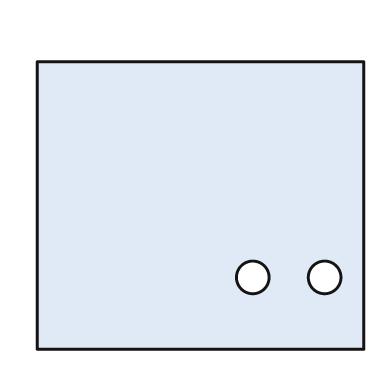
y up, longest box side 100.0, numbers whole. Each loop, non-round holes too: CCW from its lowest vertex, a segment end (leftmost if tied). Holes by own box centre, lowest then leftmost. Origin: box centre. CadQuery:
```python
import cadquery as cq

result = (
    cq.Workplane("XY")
    .moveTo(-50.0, -44.0)
    .lineTo(50.0, -44.0)
    .lineTo(50.0, 44.0)
    .lineTo(-50.0, 44.0)
    .close()
    .moveTo(16.0, -22.0)
    .circle(5.0)
    .moveTo(38.0, -22.0)
    .circle(5.0)
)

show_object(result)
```